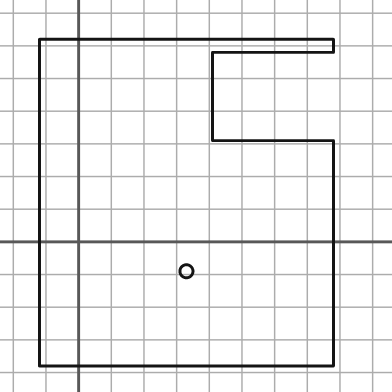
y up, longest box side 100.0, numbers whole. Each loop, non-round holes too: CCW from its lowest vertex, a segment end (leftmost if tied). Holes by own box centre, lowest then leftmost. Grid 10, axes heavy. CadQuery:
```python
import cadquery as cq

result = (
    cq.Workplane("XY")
    .moveTo(-12.0, -38.0)
    .lineTo(78.0, -38.0)
    .lineTo(78.0, 31.0)
    .lineTo(41.0, 31.0)
    .lineTo(41.0, 58.0)
    .lineTo(78.0, 58.0)
    .lineTo(78.0, 62.0)
    .lineTo(-12.0, 62.0)
    .close()
    .moveTo(33.0, -9.0)
    .circle(2.0)
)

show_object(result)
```